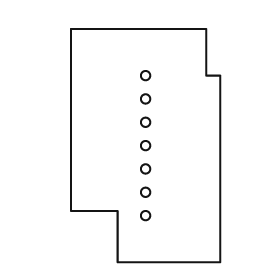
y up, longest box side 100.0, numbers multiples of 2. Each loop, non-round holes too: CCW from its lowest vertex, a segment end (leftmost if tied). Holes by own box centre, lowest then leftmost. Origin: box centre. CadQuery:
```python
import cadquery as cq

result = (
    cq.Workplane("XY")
    .moveTo(-12.0, -50.0)
    .lineTo(32.0, -50.0)
    .lineTo(32.0, 30.0)
    .lineTo(26.0, 30.0)
    .lineTo(26.0, 50.0)
    .lineTo(-32.0, 50.0)
    .lineTo(-32.0, -28.0)
    .lineTo(-12.0, -28.0)
    .close()
    .moveTo(0.0, -30.0)
    .circle(2.0)
    .moveTo(0.0, -20.0)
    .circle(2.0)
    .moveTo(0.0, -10.0)
    .circle(2.0)
    .moveTo(0.0, 0.0)
    .circle(2.0)
    .moveTo(0.0, 10.0)
    .circle(2.0)
    .moveTo(0.0, 20.0)
    .circle(2.0)
    .moveTo(0.0, 30.0)
    .circle(2.0)
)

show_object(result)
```